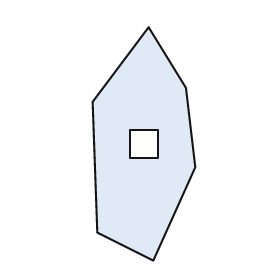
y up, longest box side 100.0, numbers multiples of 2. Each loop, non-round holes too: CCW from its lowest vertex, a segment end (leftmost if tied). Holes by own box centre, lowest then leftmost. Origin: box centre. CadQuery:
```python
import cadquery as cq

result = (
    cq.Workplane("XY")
    .moveTo(4.0, -50.0)
    .lineTo(22.0, -10.0)
    .lineTo(18.0, 24.0)
    .lineTo(2.0, 50.0)
    .lineTo(-22.0, 18.0)
    .lineTo(-20.0, -38.0)
    .close()
    .moveTo(-6.0, -6.0)
    .lineTo(6.0, -6.0)
    .lineTo(6.0, 6.0)
    .lineTo(-6.0, 6.0)
    .close()
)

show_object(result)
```